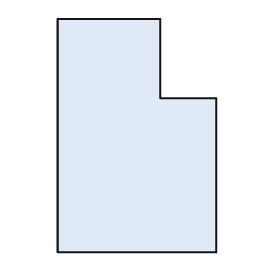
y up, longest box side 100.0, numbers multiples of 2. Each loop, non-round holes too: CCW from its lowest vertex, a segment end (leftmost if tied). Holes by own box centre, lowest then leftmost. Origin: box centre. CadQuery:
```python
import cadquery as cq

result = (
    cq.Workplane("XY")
    .moveTo(-34.0, -50.0)
    .lineTo(34.0, -50.0)
    .lineTo(34.0, 16.0)
    .lineTo(10.0, 16.0)
    .lineTo(10.0, 50.0)
    .lineTo(-34.0, 50.0)
    .close()
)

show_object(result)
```